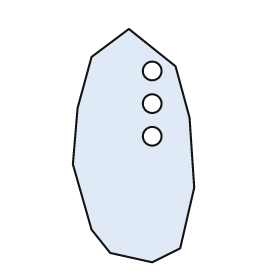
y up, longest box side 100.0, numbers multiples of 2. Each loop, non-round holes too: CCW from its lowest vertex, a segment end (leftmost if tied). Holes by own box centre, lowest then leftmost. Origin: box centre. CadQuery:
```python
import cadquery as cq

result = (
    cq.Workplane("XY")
    .moveTo(8.0, -50.0)
    .lineTo(20.0, -44.0)
    .lineTo(26.0, -18.0)
    .lineTo(24.0, 12.0)
    .lineTo(18.0, 34.0)
    .lineTo(-2.0, 50.0)
    .lineTo(-18.0, 38.0)
    .lineTo(-24.0, 16.0)
    .lineTo(-26.0, -8.0)
    .lineTo(-18.0, -36.0)
    .lineTo(-10.0, -46.0)
    .close()
    .moveTo(8.0, 4.0)
    .circle(4.0)
    .moveTo(8.0, 18.0)
    .circle(4.0)
    .moveTo(8.0, 32.0)
    .circle(4.0)
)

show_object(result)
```